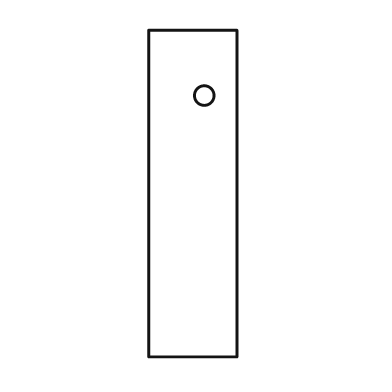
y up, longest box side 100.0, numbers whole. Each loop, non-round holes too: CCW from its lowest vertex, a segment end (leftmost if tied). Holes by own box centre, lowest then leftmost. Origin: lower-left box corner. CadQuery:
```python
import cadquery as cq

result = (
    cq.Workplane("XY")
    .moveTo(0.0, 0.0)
    .lineTo(27.0, 0.0)
    .lineTo(27.0, 100.0)
    .lineTo(0.0, 100.0)
    .close()
    .moveTo(17.0, 80.0)
    .circle(3.0)
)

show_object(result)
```